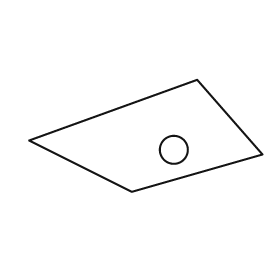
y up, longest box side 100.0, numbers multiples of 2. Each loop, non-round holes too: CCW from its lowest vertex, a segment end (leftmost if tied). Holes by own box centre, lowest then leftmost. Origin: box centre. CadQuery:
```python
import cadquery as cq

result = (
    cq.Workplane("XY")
    .moveTo(-6.0, -24.0)
    .lineTo(50.0, -8.0)
    .lineTo(22.0, 24.0)
    .lineTo(-50.0, -2.0)
    .close()
    .moveTo(12.0, -6.0)
    .circle(6.0)
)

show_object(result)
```